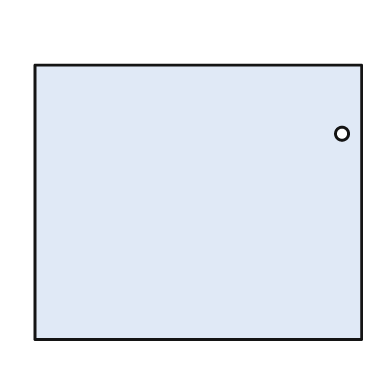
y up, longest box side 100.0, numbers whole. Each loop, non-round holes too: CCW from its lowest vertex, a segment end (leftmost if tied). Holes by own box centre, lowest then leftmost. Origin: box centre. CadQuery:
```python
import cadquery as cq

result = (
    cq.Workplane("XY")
    .moveTo(-50.0, -42.0)
    .lineTo(50.0, -42.0)
    .lineTo(50.0, 42.0)
    .lineTo(-50.0, 42.0)
    .close()
    .moveTo(44.0, 21.0)
    .circle(2.0)
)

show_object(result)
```